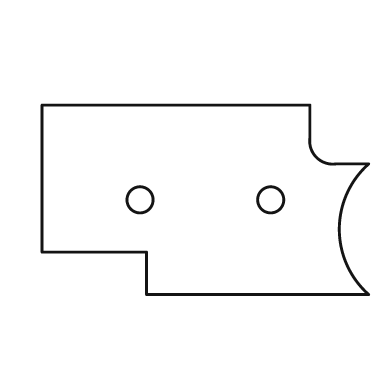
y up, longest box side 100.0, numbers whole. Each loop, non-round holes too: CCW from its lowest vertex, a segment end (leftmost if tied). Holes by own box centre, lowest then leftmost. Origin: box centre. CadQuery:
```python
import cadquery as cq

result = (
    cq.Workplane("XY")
    .moveTo(-18.0, -29.0)
    .lineTo(50.0, -29.0)
    .threePointArc((41.0, -9.0), (50.0, 11.0))
    .lineTo(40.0, 11.0)
    .threePointArc((34.0, 13.0), (32.0, 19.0))
    .lineTo(32.0, 29.0)
    .lineTo(-50.0, 29.0)
    .lineTo(-50.0, -16.0)
    .lineTo(-18.0, -16.0)
    .close()
    .moveTo(-20.0, 0.0)
    .circle(4.0)
    .moveTo(20.0, 0.0)
    .circle(4.0)
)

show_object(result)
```